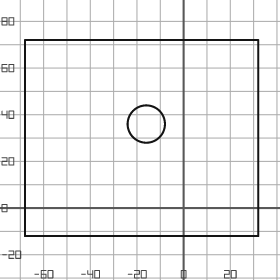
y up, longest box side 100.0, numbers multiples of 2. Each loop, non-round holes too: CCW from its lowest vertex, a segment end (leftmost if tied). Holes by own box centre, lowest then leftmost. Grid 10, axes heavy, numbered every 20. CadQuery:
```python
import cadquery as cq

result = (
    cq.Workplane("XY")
    .moveTo(-68.0, -12.0)
    .lineTo(32.0, -12.0)
    .lineTo(32.0, 72.0)
    .lineTo(-68.0, 72.0)
    .close()
    .moveTo(-16.0, 36.0)
    .circle(8.0)
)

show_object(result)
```